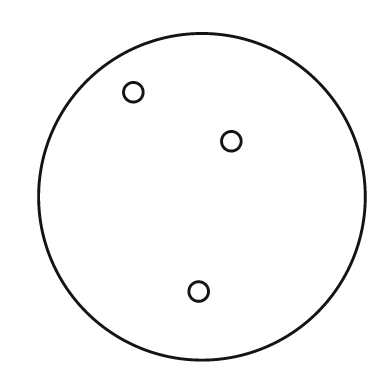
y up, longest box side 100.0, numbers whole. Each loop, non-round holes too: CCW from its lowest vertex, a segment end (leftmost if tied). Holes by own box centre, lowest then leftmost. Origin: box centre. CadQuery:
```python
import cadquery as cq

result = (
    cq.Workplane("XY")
    .moveTo(0.0, 0.0)
    .circle(50.0)
    .moveTo(-1.0, -29.0)
    .circle(3.0)
    .moveTo(9.0, 17.0)
    .circle(3.0)
    .moveTo(-21.0, 32.0)
    .circle(3.0)
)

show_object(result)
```